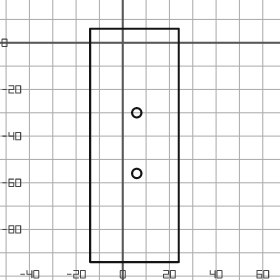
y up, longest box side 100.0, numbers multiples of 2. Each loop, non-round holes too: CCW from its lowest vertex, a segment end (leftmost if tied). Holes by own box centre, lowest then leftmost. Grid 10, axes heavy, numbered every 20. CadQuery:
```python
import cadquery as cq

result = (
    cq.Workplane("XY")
    .moveTo(-14.0, -94.0)
    .lineTo(24.0, -94.0)
    .lineTo(24.0, 6.0)
    .lineTo(-14.0, 6.0)
    .close()
    .moveTo(6.0, -56.0)
    .circle(2.0)
    .moveTo(6.0, -30.0)
    .circle(2.0)
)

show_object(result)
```